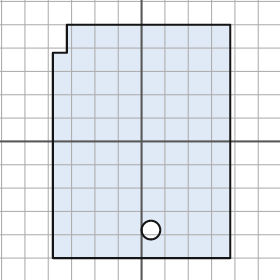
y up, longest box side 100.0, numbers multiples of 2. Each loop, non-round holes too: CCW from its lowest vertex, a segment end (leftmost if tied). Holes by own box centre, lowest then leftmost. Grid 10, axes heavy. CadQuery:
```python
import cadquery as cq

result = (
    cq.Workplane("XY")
    .moveTo(-38.0, -50.0)
    .lineTo(38.0, -50.0)
    .lineTo(38.0, 50.0)
    .lineTo(-32.0, 50.0)
    .lineTo(-32.0, 38.0)
    .lineTo(-38.0, 38.0)
    .close()
    .moveTo(4.0, -38.0)
    .circle(4.0)
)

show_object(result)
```